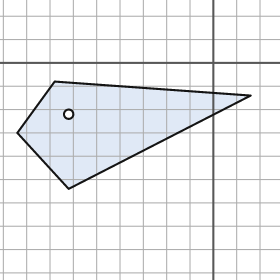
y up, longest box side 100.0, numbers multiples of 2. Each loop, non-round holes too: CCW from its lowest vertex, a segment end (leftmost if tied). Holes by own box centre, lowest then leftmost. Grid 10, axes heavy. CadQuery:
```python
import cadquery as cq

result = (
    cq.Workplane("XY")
    .moveTo(-62.0, -54.0)
    .lineTo(16.0, -14.0)
    .lineTo(-68.0, -8.0)
    .lineTo(-84.0, -30.0)
    .close()
    .moveTo(-62.0, -22.0)
    .circle(2.0)
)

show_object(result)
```